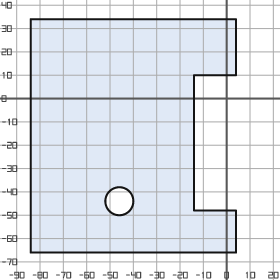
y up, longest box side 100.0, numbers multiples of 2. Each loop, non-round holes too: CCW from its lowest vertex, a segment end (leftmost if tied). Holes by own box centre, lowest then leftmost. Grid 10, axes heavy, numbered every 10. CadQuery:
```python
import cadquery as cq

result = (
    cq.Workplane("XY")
    .moveTo(-84.0, -66.0)
    .lineTo(4.0, -66.0)
    .lineTo(4.0, -48.0)
    .lineTo(-14.0, -48.0)
    .lineTo(-14.0, 10.0)
    .lineTo(4.0, 10.0)
    .lineTo(4.0, 34.0)
    .lineTo(-84.0, 34.0)
    .close()
    .moveTo(-46.0, -44.0)
    .circle(6.0)
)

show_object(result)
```